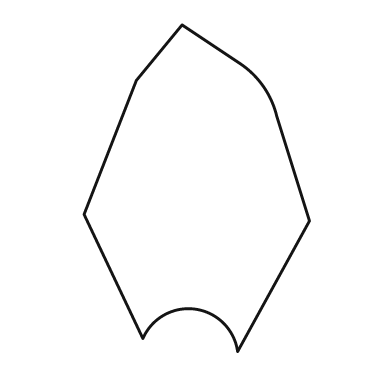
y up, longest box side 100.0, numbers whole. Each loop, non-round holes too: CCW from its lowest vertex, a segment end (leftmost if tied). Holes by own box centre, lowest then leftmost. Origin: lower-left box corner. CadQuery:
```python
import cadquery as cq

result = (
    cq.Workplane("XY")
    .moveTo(47.0, 0.0)
    .lineTo(69.0, 40.0)
    .lineTo(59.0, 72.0)
    .threePointArc((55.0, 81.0), (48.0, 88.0))
    .lineTo(30.0, 100.0)
    .lineTo(16.0, 83.0)
    .lineTo(0.0, 42.0)
    .lineTo(18.0, 4.0)
    .threePointArc((34.0, 13.0), (47.0, 0.0))
    .close()
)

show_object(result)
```